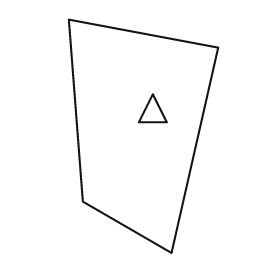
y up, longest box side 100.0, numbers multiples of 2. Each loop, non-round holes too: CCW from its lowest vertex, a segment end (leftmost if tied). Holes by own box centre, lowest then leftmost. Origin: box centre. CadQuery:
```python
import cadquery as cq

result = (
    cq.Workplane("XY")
    .moveTo(12.0, -50.0)
    .lineTo(32.0, 38.0)
    .lineTo(-32.0, 50.0)
    .lineTo(-26.0, -28.0)
    .close()
    .moveTo(-2.0, 6.0)
    .lineTo(10.0, 6.0)
    .lineTo(4.0, 18.0)
    .close()
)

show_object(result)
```